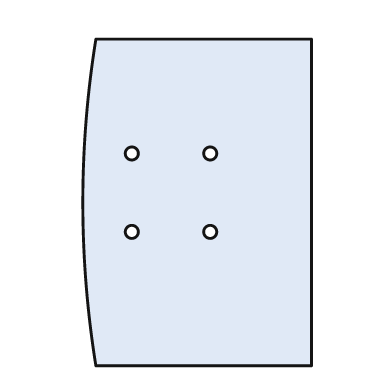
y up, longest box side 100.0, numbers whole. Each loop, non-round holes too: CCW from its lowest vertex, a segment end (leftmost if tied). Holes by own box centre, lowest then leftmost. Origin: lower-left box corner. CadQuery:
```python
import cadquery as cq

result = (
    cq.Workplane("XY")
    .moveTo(4.0, 0.0)
    .lineTo(70.0, 0.0)
    .lineTo(70.0, 100.0)
    .lineTo(4.0, 100.0)
    .threePointArc((0.0, 50.0), (4.0, 0.0))
    .close()
    .moveTo(15.0, 41.0)
    .circle(2.0)
    .moveTo(39.0, 41.0)
    .circle(2.0)
    .moveTo(15.0, 65.0)
    .circle(2.0)
    .moveTo(39.0, 65.0)
    .circle(2.0)
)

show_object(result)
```